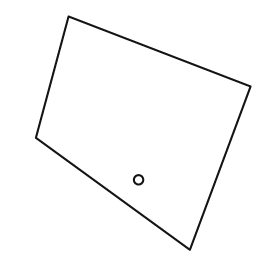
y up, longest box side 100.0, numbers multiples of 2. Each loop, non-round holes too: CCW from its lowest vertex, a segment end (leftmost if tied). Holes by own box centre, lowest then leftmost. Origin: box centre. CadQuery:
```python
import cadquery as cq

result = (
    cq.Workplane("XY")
    .moveTo(20.0, -50.0)
    .lineTo(46.0, 20.0)
    .lineTo(-32.0, 50.0)
    .lineTo(-46.0, -2.0)
    .close()
    .moveTo(-2.0, -20.0)
    .circle(2.0)
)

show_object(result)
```